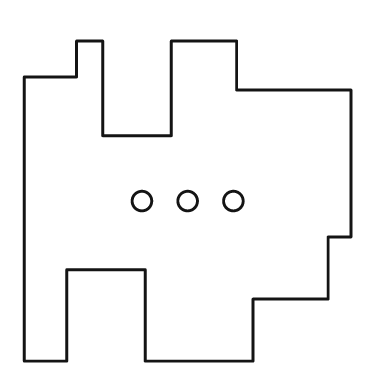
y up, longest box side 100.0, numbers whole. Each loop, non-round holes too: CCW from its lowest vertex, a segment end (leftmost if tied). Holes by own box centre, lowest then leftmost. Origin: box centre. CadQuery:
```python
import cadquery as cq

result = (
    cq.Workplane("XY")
    .moveTo(-50.0, -49.0)
    .lineTo(-37.0, -49.0)
    .lineTo(-37.0, -21.0)
    .lineTo(-13.0, -21.0)
    .lineTo(-13.0, -49.0)
    .lineTo(20.0, -49.0)
    .lineTo(20.0, -30.0)
    .lineTo(43.0, -30.0)
    .lineTo(43.0, -11.0)
    .lineTo(50.0, -11.0)
    .lineTo(50.0, 34.0)
    .lineTo(15.0, 34.0)
    .lineTo(15.0, 49.0)
    .lineTo(-5.0, 49.0)
    .lineTo(-5.0, 20.0)
    .lineTo(-26.0, 20.0)
    .lineTo(-26.0, 49.0)
    .lineTo(-34.0, 49.0)
    .lineTo(-34.0, 38.0)
    .lineTo(-50.0, 38.0)
    .close()
    .moveTo(-14.0, 0.0)
    .circle(3.0)
    .moveTo(0.0, 0.0)
    .circle(3.0)
    .moveTo(14.0, 0.0)
    .circle(3.0)
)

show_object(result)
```